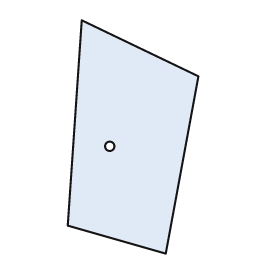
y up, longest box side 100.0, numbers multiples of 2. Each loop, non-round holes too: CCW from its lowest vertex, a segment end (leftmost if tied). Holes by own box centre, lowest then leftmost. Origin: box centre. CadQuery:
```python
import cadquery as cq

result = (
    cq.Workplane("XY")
    .moveTo(14.0, -50.0)
    .lineTo(28.0, 26.0)
    .lineTo(-22.0, 50.0)
    .lineTo(-28.0, -38.0)
    .close()
    .moveTo(-10.0, -4.0)
    .circle(2.0)
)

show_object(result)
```